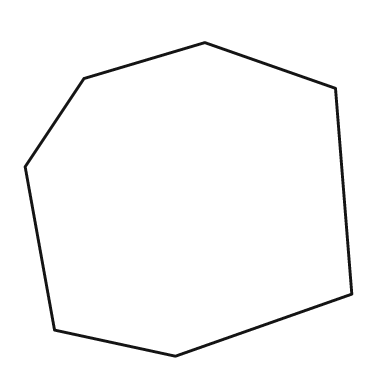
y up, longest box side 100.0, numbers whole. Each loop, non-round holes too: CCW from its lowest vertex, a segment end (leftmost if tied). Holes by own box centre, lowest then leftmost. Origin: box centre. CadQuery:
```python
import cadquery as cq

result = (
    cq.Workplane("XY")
    .moveTo(-4.0, -48.0)
    .lineTo(50.0, -29.0)
    .lineTo(45.0, 34.0)
    .lineTo(5.0, 48.0)
    .lineTo(-32.0, 37.0)
    .lineTo(-50.0, 10.0)
    .lineTo(-41.0, -40.0)
    .close()
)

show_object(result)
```